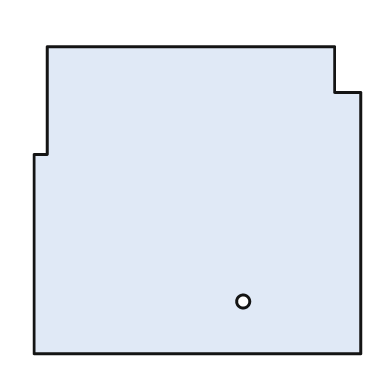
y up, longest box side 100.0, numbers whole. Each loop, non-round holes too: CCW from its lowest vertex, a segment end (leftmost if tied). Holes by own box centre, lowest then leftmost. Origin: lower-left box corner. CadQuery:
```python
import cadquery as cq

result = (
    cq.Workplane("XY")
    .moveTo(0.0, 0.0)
    .lineTo(100.0, 0.0)
    .lineTo(100.0, 80.0)
    .lineTo(92.0, 80.0)
    .lineTo(92.0, 94.0)
    .lineTo(4.0, 94.0)
    .lineTo(4.0, 61.0)
    .lineTo(0.0, 61.0)
    .close()
    .moveTo(64.0, 16.0)
    .circle(2.0)
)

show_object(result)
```